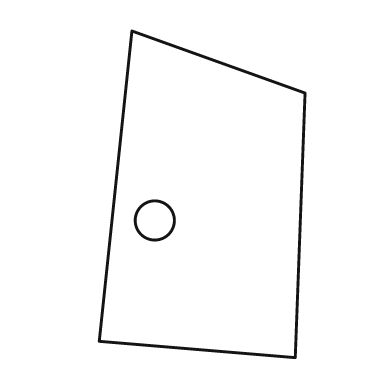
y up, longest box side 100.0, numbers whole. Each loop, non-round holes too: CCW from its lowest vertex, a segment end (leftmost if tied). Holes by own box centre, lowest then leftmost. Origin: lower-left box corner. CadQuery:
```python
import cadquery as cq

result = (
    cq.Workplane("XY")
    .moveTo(60.0, 0.0)
    .lineTo(63.0, 81.0)
    .lineTo(10.0, 100.0)
    .lineTo(0.0, 5.0)
    .close()
    .moveTo(17.0, 42.0)
    .circle(6.0)
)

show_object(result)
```